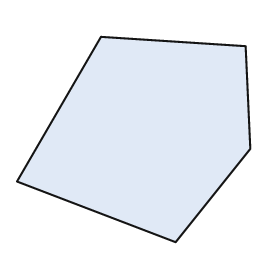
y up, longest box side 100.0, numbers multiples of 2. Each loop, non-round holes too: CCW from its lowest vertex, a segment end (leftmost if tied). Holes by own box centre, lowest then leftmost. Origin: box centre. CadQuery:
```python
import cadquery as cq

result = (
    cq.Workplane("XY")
    .moveTo(18.0, -44.0)
    .lineTo(50.0, -4.0)
    .lineTo(48.0, 40.0)
    .lineTo(-14.0, 44.0)
    .lineTo(-50.0, -18.0)
    .close()
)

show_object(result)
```